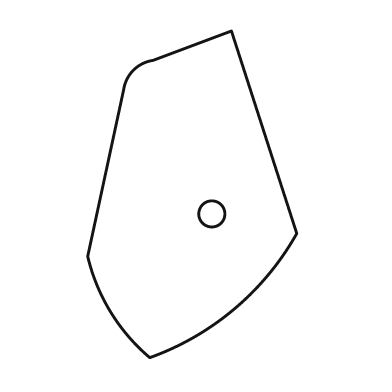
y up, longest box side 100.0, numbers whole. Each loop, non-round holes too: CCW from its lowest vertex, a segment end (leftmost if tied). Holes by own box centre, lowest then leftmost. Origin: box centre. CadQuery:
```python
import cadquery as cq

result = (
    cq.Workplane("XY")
    .moveTo(-13.0, -50.0)
    .threePointArc((13.0, -35.0), (32.0, -12.0))
    .lineTo(12.0, 50.0)
    .lineTo(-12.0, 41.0)
    .threePointArc((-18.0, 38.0), (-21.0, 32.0))
    .lineTo(-32.0, -19.0)
    .threePointArc((-25.0, -36.0), (-13.0, -50.0))
    .close()
    .moveTo(6.0, -6.0)
    .circle(4.0)
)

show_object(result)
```